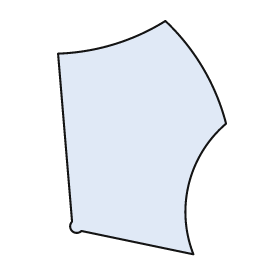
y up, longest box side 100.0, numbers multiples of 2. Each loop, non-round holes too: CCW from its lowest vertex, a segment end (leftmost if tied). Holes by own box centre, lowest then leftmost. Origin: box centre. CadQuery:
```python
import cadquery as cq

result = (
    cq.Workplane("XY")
    .moveTo(22.0, -50.0)
    .threePointArc((20.0, -20.0), (36.0, 6.0))
    .threePointArc((26.0, 30.0), (10.0, 50.0))
    .threePointArc((-12.0, 40.0), (-36.0, 36.0))
    .lineTo(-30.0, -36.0)
    .threePointArc((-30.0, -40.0), (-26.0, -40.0))
    .close()
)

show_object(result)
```